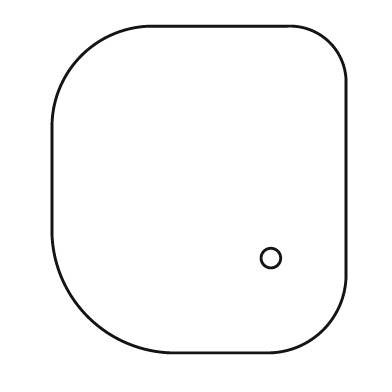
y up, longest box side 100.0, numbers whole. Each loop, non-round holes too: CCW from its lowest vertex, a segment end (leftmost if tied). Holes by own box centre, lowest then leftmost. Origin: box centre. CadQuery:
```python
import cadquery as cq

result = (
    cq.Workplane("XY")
    .moveTo(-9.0, -50.0)
    .lineTo(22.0, -50.0)
    .threePointArc((38.0, -43.0), (45.0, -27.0))
    .lineTo(45.0, 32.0)
    .threePointArc((40.0, 45.0), (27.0, 50.0))
    .lineTo(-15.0, 50.0)
    .threePointArc((-36.0, 41.0), (-45.0, 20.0))
    .lineTo(-45.0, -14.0)
    .threePointArc((-34.0, -39.0), (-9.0, -50.0))
    .close()
    .moveTo(22.0, -21.0)
    .circle(3.0)
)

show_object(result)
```